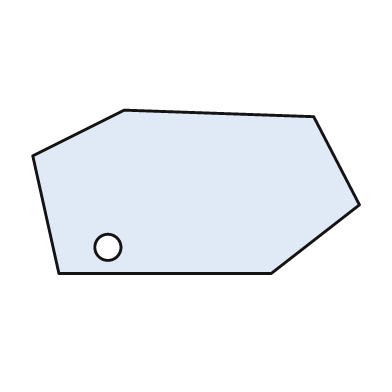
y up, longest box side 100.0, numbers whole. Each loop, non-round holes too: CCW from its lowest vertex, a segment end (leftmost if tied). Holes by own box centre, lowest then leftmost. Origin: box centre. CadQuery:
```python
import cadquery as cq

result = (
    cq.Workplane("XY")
    .moveTo(-42.0, -25.0)
    .lineTo(23.0, -25.0)
    .lineTo(50.0, -4.0)
    .lineTo(36.0, 23.0)
    .lineTo(-22.0, 25.0)
    .lineTo(-50.0, 11.0)
    .close()
    .moveTo(-27.0, -17.0)
    .circle(4.0)
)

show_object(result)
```